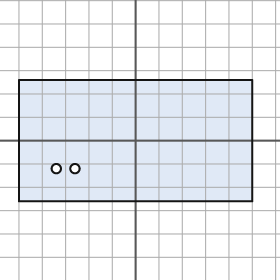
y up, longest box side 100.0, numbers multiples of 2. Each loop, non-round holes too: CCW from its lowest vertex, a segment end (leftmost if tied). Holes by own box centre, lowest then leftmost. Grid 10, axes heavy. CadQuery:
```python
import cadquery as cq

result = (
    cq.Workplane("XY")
    .moveTo(-50.0, -26.0)
    .lineTo(50.0, -26.0)
    .lineTo(50.0, 26.0)
    .lineTo(-50.0, 26.0)
    .close()
    .moveTo(-34.0, -12.0)
    .circle(2.0)
    .moveTo(-26.0, -12.0)
    .circle(2.0)
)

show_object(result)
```